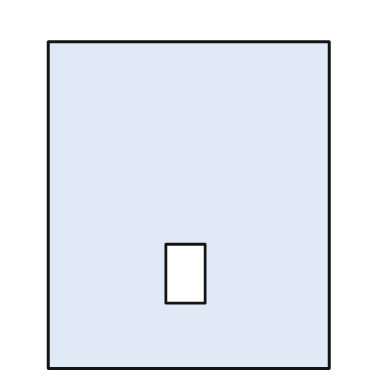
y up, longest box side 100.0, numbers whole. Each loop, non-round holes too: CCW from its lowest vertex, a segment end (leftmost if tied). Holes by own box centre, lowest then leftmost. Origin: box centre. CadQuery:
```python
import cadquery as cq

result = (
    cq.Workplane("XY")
    .moveTo(-43.0, -50.0)
    .lineTo(43.0, -50.0)
    .lineTo(43.0, 50.0)
    .lineTo(-43.0, 50.0)
    .close()
    .moveTo(-7.0, -30.0)
    .lineTo(5.0, -30.0)
    .lineTo(5.0, -12.0)
    .lineTo(-7.0, -12.0)
    .close()
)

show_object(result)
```